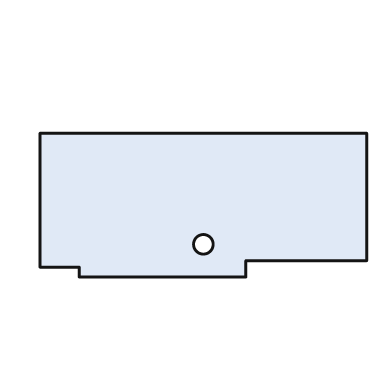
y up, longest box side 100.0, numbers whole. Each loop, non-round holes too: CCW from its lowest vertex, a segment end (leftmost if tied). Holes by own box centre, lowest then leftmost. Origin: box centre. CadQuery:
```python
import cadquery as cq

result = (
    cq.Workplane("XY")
    .moveTo(-38.0, -22.0)
    .lineTo(13.0, -22.0)
    .lineTo(13.0, -17.0)
    .lineTo(50.0, -17.0)
    .lineTo(50.0, 22.0)
    .lineTo(-50.0, 22.0)
    .lineTo(-50.0, -19.0)
    .lineTo(-38.0, -19.0)
    .close()
    .moveTo(0.0, -12.0)
    .circle(3.0)
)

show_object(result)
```